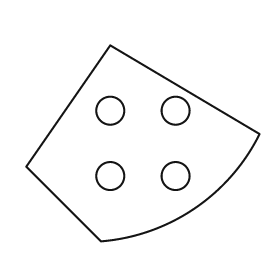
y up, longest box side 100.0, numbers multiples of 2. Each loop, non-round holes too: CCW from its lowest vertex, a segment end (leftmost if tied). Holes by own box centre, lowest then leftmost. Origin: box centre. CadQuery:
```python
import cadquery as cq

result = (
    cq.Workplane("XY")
    .moveTo(-18.0, -42.0)
    .threePointArc((22.0, -28.0), (50.0, 4.0))
    .lineTo(-14.0, 42.0)
    .lineTo(-50.0, -10.0)
    .close()
    .moveTo(-14.0, -14.0)
    .circle(6.0)
    .moveTo(14.0, -14.0)
    .circle(6.0)
    .moveTo(-14.0, 14.0)
    .circle(6.0)
    .moveTo(14.0, 14.0)
    .circle(6.0)
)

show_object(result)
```